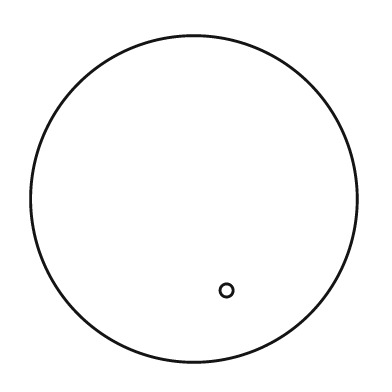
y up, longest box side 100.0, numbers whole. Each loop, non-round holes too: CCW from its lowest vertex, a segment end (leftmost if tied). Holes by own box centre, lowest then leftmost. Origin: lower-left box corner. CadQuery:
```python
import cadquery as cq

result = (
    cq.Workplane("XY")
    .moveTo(50.0, 50.0)
    .circle(50.0)
    .moveTo(60.0, 22.0)
    .circle(2.0)
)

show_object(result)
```